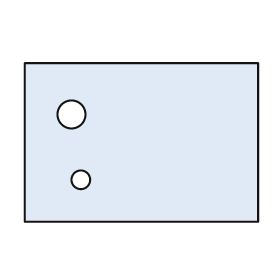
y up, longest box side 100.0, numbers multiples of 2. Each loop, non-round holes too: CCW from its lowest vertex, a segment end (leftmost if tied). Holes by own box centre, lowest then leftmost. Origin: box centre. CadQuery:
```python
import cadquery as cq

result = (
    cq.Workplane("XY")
    .moveTo(-50.0, -34.0)
    .lineTo(50.0, -34.0)
    .lineTo(50.0, 34.0)
    .lineTo(-50.0, 34.0)
    .close()
    .moveTo(-26.0, -16.0)
    .circle(4.0)
    .moveTo(-30.0, 12.0)
    .circle(6.0)
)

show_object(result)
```